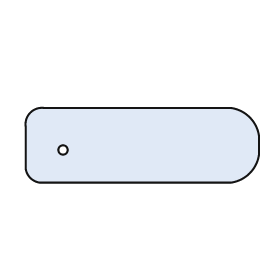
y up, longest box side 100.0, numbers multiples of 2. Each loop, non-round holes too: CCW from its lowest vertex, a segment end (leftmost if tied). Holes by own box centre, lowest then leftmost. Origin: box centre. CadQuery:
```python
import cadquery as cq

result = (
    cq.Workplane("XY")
    .moveTo(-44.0, -16.0)
    .lineTo(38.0, -16.0)
    .threePointArc((46.0, -12.0), (50.0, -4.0))
    .lineTo(50.0, 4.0)
    .threePointArc((46.0, 12.0), (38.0, 16.0))
    .lineTo(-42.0, 16.0)
    .threePointArc((-48.0, 14.0), (-50.0, 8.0))
    .lineTo(-50.0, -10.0)
    .threePointArc((-48.0, -14.0), (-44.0, -16.0))
    .close()
    .moveTo(-34.0, -2.0)
    .circle(2.0)
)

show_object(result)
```